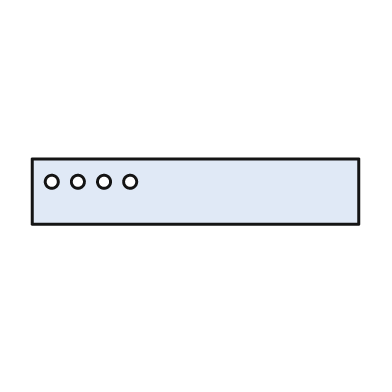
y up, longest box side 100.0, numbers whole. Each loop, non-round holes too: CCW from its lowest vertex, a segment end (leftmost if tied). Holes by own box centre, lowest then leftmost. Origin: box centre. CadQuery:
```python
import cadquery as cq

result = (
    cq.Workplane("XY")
    .moveTo(-50.0, -10.0)
    .lineTo(50.0, -10.0)
    .lineTo(50.0, 10.0)
    .lineTo(-50.0, 10.0)
    .close()
    .moveTo(-44.0, 3.0)
    .circle(2.0)
    .moveTo(-36.0, 3.0)
    .circle(2.0)
    .moveTo(-28.0, 3.0)
    .circle(2.0)
    .moveTo(-20.0, 3.0)
    .circle(2.0)
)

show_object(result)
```